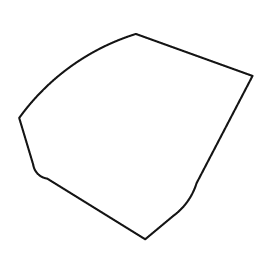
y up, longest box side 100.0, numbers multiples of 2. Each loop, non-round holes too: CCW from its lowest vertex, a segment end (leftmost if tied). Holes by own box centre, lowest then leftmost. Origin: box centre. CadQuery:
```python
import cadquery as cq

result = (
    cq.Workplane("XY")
    .moveTo(4.0, -44.0)
    .lineTo(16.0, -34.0)
    .threePointArc((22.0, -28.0), (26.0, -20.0))
    .lineTo(50.0, 26.0)
    .lineTo(0.0, 44.0)
    .threePointArc((-28.0, 30.0), (-50.0, 8.0))
    .lineTo(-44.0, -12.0)
    .threePointArc((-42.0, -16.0), (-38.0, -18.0))
    .close()
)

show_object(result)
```